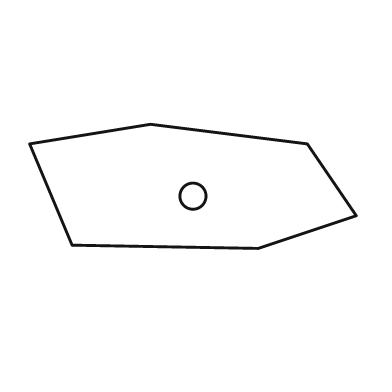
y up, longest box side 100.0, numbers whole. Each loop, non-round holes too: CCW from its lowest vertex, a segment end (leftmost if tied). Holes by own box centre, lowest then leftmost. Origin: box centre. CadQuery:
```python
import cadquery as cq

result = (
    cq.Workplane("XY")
    .moveTo(20.0, -19.0)
    .lineTo(50.0, -9.0)
    .lineTo(35.0, 13.0)
    .lineTo(-13.0, 19.0)
    .lineTo(-50.0, 13.0)
    .lineTo(-37.0, -18.0)
    .close()
    .moveTo(0.0, -3.0)
    .circle(4.0)
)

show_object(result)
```